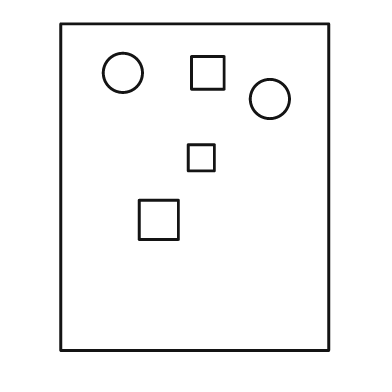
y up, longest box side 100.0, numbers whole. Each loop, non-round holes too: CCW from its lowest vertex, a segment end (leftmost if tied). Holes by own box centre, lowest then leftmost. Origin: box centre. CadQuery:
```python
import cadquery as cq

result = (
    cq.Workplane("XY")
    .moveTo(-41.0, -50.0)
    .lineTo(41.0, -50.0)
    .lineTo(41.0, 50.0)
    .lineTo(-41.0, 50.0)
    .close()
    .moveTo(-17.0, -16.0)
    .lineTo(-5.0, -16.0)
    .lineTo(-5.0, -4.0)
    .lineTo(-17.0, -4.0)
    .close()
    .moveTo(-2.0, 5.0)
    .lineTo(6.0, 5.0)
    .lineTo(6.0, 13.0)
    .lineTo(-2.0, 13.0)
    .close()
    .moveTo(23.0, 27.0)
    .circle(6.0)
    .moveTo(-22.0, 35.0)
    .circle(6.0)
    .moveTo(-1.0, 30.0)
    .lineTo(9.0, 30.0)
    .lineTo(9.0, 40.0)
    .lineTo(-1.0, 40.0)
    .close()
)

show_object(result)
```